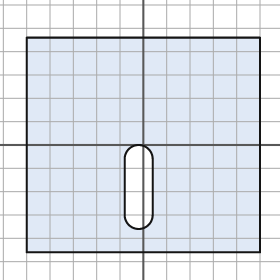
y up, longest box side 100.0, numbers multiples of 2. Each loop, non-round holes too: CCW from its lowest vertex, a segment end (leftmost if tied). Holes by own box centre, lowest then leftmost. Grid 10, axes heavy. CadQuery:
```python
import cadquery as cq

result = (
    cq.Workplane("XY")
    .moveTo(-50.0, -46.0)
    .lineTo(50.0, -46.0)
    .lineTo(50.0, 46.0)
    .lineTo(-50.0, 46.0)
    .close()
    .moveTo(-8.0, -30.0)
    .threePointArc((-2.0, -36.0), (4.0, -30.0))
    .lineTo(4.0, -6.0)
    .threePointArc((-2.0, 0.0), (-8.0, -6.0))
    .close()
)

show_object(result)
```